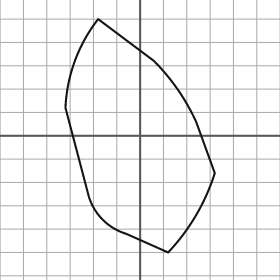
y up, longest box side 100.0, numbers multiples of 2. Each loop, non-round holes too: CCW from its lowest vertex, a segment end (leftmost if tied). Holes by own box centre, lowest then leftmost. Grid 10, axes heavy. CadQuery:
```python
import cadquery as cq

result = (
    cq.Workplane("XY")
    .moveTo(12.0, -50.0)
    .threePointArc((24.0, -34.0), (32.0, -16.0))
    .lineTo(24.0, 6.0)
    .threePointArc((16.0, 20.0), (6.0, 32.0))
    .lineTo(-18.0, 50.0)
    .threePointArc((-28.0, 32.0), (-32.0, 12.0))
    .lineTo(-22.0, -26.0)
    .threePointArc((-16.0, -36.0), (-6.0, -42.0))
    .close()
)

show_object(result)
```